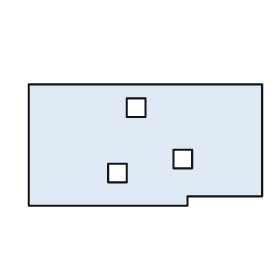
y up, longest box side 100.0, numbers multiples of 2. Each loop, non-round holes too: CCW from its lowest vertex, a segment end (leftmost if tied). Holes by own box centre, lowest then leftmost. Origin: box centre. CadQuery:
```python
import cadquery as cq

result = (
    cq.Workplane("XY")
    .moveTo(-50.0, -26.0)
    .lineTo(18.0, -26.0)
    .lineTo(18.0, -22.0)
    .lineTo(50.0, -22.0)
    .lineTo(50.0, 26.0)
    .lineTo(-50.0, 26.0)
    .close()
    .moveTo(-16.0, -16.0)
    .lineTo(-8.0, -16.0)
    .lineTo(-8.0, -8.0)
    .lineTo(-16.0, -8.0)
    .close()
    .moveTo(12.0, -10.0)
    .lineTo(20.0, -10.0)
    .lineTo(20.0, -2.0)
    .lineTo(12.0, -2.0)
    .close()
    .moveTo(-8.0, 12.0)
    .lineTo(0.0, 12.0)
    .lineTo(0.0, 20.0)
    .lineTo(-8.0, 20.0)
    .close()
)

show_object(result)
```